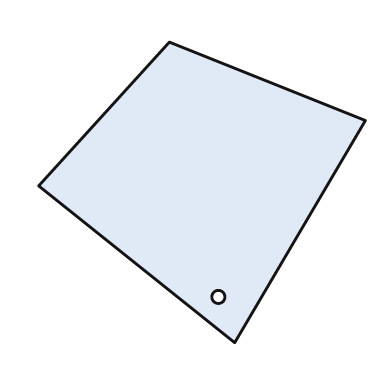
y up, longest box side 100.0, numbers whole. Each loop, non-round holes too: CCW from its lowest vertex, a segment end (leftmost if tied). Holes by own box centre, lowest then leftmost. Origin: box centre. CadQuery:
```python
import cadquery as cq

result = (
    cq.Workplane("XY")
    .moveTo(10.0, -46.0)
    .lineTo(50.0, 22.0)
    .lineTo(-10.0, 46.0)
    .lineTo(-50.0, 2.0)
    .close()
    .moveTo(5.0, -32.0)
    .circle(2.0)
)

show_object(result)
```